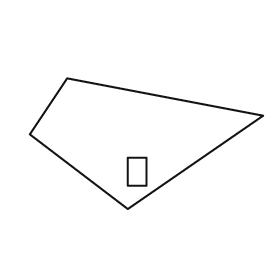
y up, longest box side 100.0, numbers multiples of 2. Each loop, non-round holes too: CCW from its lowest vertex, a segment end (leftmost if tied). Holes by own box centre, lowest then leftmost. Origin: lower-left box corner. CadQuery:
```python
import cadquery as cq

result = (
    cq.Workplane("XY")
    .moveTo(42.0, 0.0)
    .lineTo(100.0, 40.0)
    .lineTo(16.0, 56.0)
    .lineTo(0.0, 32.0)
    .close()
    .moveTo(42.0, 10.0)
    .lineTo(50.0, 10.0)
    .lineTo(50.0, 22.0)
    .lineTo(42.0, 22.0)
    .close()
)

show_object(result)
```